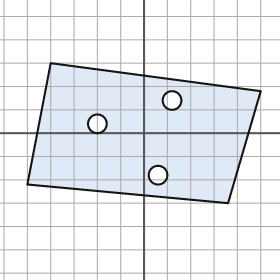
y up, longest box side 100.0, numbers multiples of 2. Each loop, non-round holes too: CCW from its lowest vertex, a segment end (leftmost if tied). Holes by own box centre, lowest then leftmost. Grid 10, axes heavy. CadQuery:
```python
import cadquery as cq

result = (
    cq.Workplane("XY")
    .moveTo(36.0, -30.0)
    .lineTo(50.0, 18.0)
    .lineTo(-40.0, 30.0)
    .lineTo(-50.0, -22.0)
    .close()
    .moveTo(6.0, -18.0)
    .circle(4.0)
    .moveTo(-20.0, 4.0)
    .circle(4.0)
    .moveTo(12.0, 14.0)
    .circle(4.0)
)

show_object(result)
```